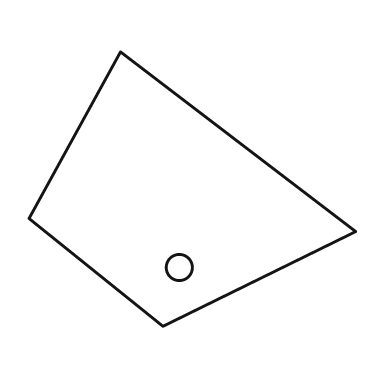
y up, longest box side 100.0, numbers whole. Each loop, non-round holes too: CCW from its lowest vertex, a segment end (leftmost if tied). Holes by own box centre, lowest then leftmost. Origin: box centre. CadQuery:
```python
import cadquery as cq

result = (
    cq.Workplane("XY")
    .moveTo(-9.0, -42.0)
    .lineTo(50.0, -13.0)
    .lineTo(-22.0, 42.0)
    .lineTo(-50.0, -9.0)
    .close()
    .moveTo(-4.0, -24.0)
    .circle(4.0)
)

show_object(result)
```